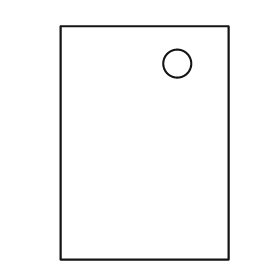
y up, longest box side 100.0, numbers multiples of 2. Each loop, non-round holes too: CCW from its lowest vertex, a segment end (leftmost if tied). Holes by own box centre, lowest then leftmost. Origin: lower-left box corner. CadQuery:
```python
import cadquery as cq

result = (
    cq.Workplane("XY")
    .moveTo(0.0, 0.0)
    .lineTo(72.0, 0.0)
    .lineTo(72.0, 100.0)
    .lineTo(0.0, 100.0)
    .close()
    .moveTo(50.0, 84.0)
    .circle(6.0)
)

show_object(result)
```